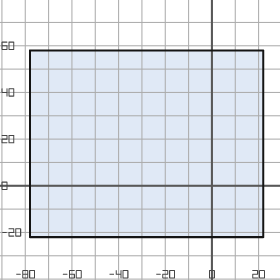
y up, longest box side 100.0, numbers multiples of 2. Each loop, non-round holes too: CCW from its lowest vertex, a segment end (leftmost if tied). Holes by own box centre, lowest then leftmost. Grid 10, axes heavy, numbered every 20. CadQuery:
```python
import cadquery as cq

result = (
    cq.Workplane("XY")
    .moveTo(-78.0, -22.0)
    .lineTo(22.0, -22.0)
    .lineTo(22.0, 58.0)
    .lineTo(-78.0, 58.0)
    .close()
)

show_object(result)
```